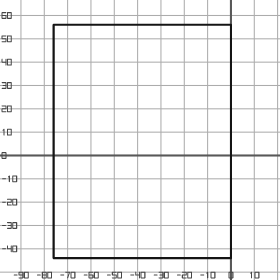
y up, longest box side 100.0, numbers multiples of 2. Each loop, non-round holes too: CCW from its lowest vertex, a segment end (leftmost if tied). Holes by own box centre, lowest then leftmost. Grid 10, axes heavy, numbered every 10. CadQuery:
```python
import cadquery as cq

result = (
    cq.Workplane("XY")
    .moveTo(-76.0, -44.0)
    .lineTo(0.0, -44.0)
    .lineTo(0.0, 56.0)
    .lineTo(-76.0, 56.0)
    .close()
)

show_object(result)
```